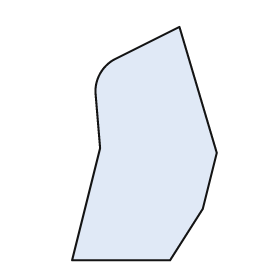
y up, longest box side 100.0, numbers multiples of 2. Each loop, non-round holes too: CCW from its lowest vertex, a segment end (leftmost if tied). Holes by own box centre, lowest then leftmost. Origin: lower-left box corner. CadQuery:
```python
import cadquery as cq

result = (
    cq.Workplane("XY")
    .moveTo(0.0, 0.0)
    .lineTo(42.0, 0.0)
    .lineTo(56.0, 22.0)
    .lineTo(62.0, 46.0)
    .lineTo(46.0, 100.0)
    .lineTo(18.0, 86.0)
    .threePointArc((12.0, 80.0), (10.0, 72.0))
    .lineTo(12.0, 48.0)
    .close()
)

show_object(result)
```